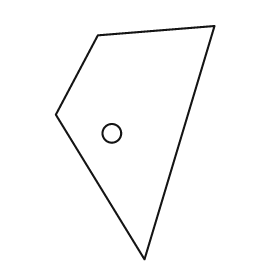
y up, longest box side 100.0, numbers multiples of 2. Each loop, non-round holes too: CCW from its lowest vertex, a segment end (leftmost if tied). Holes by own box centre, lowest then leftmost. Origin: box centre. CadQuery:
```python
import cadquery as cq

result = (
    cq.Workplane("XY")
    .moveTo(4.0, -50.0)
    .lineTo(34.0, 50.0)
    .lineTo(-16.0, 46.0)
    .lineTo(-34.0, 12.0)
    .close()
    .moveTo(-10.0, 4.0)
    .circle(4.0)
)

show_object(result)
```